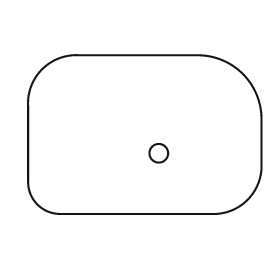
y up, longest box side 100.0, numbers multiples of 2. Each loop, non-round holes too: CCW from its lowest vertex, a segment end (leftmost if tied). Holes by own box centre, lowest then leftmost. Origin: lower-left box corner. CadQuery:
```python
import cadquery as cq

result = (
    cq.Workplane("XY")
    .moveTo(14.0, 0.0)
    .lineTo(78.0, 0.0)
    .threePointArc((94.0, 6.0), (100.0, 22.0))
    .lineTo(100.0, 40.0)
    .threePointArc((92.0, 60.0), (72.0, 68.0))
    .lineTo(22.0, 68.0)
    .threePointArc((6.0, 62.0), (0.0, 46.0))
    .lineTo(0.0, 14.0)
    .threePointArc((4.0, 4.0), (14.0, 0.0))
    .close()
    .moveTo(56.0, 26.0)
    .circle(4.0)
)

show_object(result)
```